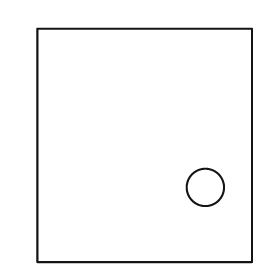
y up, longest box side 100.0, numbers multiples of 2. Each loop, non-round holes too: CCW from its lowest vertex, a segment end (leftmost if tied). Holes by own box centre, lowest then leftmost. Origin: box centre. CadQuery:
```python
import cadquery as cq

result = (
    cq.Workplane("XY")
    .moveTo(-46.0, -50.0)
    .lineTo(46.0, -50.0)
    .lineTo(46.0, 50.0)
    .lineTo(-46.0, 50.0)
    .close()
    .moveTo(26.0, -18.0)
    .circle(8.0)
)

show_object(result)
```